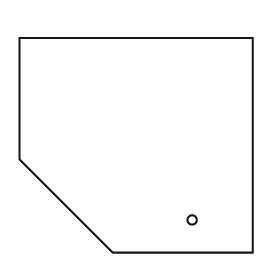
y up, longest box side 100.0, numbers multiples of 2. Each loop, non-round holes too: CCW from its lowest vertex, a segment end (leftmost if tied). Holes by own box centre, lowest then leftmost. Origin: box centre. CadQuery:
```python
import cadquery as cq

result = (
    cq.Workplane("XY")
    .moveTo(-10.0, -46.0)
    .lineTo(50.0, -46.0)
    .lineTo(50.0, 46.0)
    .lineTo(-50.0, 46.0)
    .lineTo(-50.0, -6.0)
    .close()
    .moveTo(24.0, -32.0)
    .circle(2.0)
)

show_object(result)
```